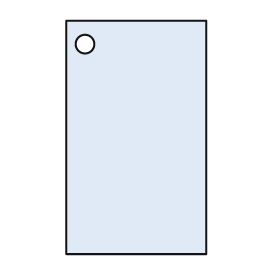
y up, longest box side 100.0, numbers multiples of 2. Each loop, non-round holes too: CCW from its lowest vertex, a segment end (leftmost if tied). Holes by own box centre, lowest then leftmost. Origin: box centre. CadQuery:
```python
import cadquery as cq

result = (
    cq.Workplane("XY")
    .moveTo(-30.0, -50.0)
    .lineTo(30.0, -50.0)
    .lineTo(30.0, 50.0)
    .lineTo(-30.0, 50.0)
    .close()
    .moveTo(-22.0, 40.0)
    .circle(4.0)
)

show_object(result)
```